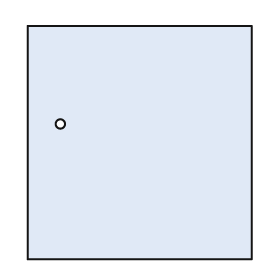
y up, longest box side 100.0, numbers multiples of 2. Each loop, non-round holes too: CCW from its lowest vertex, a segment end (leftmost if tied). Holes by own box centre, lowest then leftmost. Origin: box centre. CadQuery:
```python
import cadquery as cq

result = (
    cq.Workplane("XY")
    .moveTo(-48.0, -50.0)
    .lineTo(48.0, -50.0)
    .lineTo(48.0, 50.0)
    .lineTo(-48.0, 50.0)
    .close()
    .moveTo(-34.0, 8.0)
    .circle(2.0)
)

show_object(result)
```